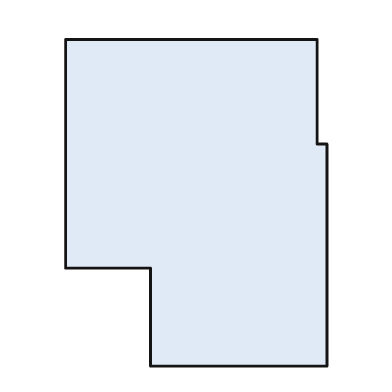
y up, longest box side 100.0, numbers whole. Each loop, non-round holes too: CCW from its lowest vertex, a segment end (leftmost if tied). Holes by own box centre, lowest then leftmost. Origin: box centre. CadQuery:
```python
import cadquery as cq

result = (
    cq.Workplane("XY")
    .moveTo(-14.0, -50.0)
    .lineTo(40.0, -50.0)
    .lineTo(40.0, 18.0)
    .lineTo(37.0, 18.0)
    .lineTo(37.0, 50.0)
    .lineTo(-40.0, 50.0)
    .lineTo(-40.0, -20.0)
    .lineTo(-14.0, -20.0)
    .close()
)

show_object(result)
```